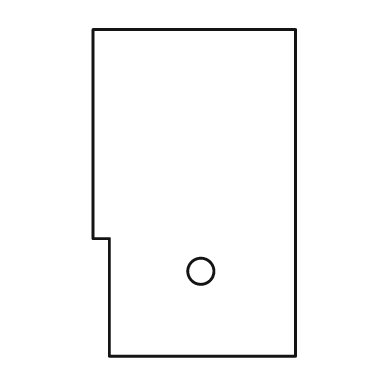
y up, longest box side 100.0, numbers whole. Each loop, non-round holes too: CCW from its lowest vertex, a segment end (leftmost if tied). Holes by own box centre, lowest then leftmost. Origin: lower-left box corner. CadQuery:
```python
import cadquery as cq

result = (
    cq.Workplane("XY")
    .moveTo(5.0, 0.0)
    .lineTo(62.0, 0.0)
    .lineTo(62.0, 100.0)
    .lineTo(0.0, 100.0)
    .lineTo(0.0, 36.0)
    .lineTo(5.0, 36.0)
    .close()
    .moveTo(33.0, 26.0)
    .circle(4.0)
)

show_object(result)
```